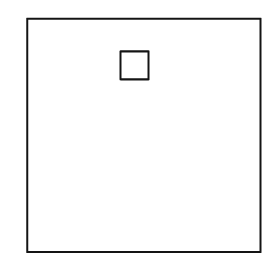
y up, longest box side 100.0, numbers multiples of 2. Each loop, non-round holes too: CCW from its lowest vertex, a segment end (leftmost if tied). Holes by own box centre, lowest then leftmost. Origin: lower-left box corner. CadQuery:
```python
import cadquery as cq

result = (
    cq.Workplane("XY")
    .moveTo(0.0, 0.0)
    .lineTo(100.0, 0.0)
    .lineTo(100.0, 100.0)
    .lineTo(0.0, 100.0)
    .close()
    .moveTo(40.0, 74.0)
    .lineTo(52.0, 74.0)
    .lineTo(52.0, 86.0)
    .lineTo(40.0, 86.0)
    .close()
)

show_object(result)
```